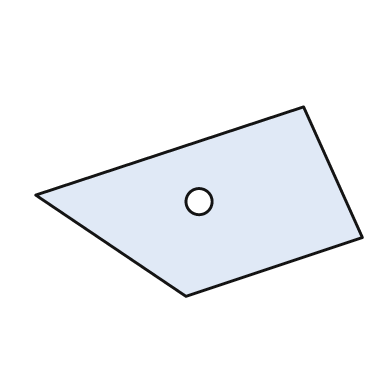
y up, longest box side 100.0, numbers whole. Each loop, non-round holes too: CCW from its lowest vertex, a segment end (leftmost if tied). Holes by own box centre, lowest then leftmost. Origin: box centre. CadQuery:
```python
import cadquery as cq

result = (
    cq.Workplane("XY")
    .moveTo(-4.0, -29.0)
    .lineTo(50.0, -11.0)
    .lineTo(32.0, 29.0)
    .lineTo(-50.0, 2.0)
    .close()
    .moveTo(0.0, 0.0)
    .circle(4.0)
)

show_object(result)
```